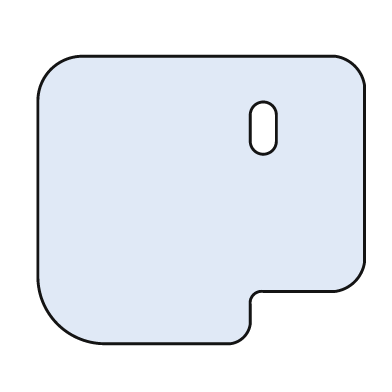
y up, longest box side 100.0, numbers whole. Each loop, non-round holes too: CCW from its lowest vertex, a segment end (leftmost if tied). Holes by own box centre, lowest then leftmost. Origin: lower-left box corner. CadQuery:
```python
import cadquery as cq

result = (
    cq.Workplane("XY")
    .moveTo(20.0, 0.0)
    .lineTo(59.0, 0.0)
    .threePointArc((63.0, 2.0), (65.0, 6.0))
    .lineTo(65.0, 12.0)
    .threePointArc((66.0, 15.0), (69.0, 16.0))
    .lineTo(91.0, 16.0)
    .threePointArc((97.0, 19.0), (100.0, 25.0))
    .lineTo(100.0, 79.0)
    .threePointArc((97.0, 85.0), (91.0, 88.0))
    .lineTo(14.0, 88.0)
    .threePointArc((4.0, 84.0), (0.0, 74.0))
    .lineTo(0.0, 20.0)
    .threePointArc((6.0, 6.0), (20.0, 0.0))
    .close()
    .moveTo(65.0, 62.0)
    .threePointArc((69.0, 58.0), (73.0, 62.0))
    .lineTo(73.0, 70.0)
    .threePointArc((69.0, 74.0), (65.0, 70.0))
    .close()
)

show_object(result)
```